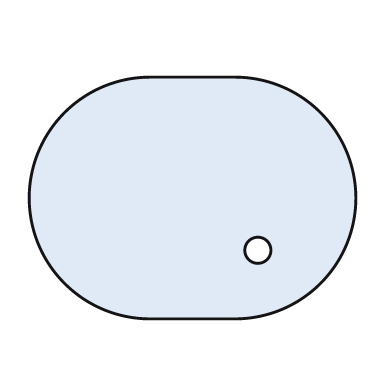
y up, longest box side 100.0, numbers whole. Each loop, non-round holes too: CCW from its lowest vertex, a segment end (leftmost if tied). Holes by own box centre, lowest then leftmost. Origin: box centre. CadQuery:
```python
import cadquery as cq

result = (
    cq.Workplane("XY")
    .moveTo(-13.0, -37.0)
    .lineTo(13.0, -37.0)
    .threePointArc((50.0, 0.0), (13.0, 37.0))
    .lineTo(-13.0, 37.0)
    .threePointArc((-50.0, 0.0), (-13.0, -37.0))
    .close()
    .moveTo(20.0, -16.0)
    .circle(4.0)
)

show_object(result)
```